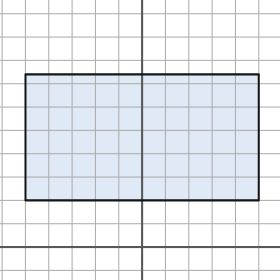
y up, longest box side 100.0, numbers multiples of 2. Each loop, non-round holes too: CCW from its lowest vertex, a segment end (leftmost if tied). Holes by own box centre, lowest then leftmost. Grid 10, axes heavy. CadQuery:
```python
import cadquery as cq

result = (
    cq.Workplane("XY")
    .moveTo(-50.0, 20.0)
    .lineTo(50.0, 20.0)
    .lineTo(50.0, 74.0)
    .lineTo(-50.0, 74.0)
    .close()
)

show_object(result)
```